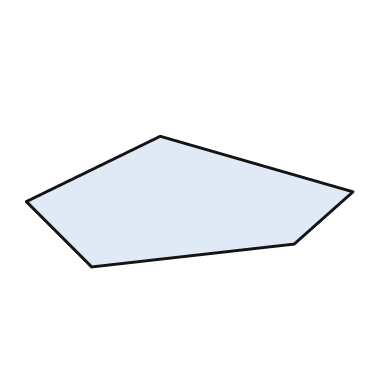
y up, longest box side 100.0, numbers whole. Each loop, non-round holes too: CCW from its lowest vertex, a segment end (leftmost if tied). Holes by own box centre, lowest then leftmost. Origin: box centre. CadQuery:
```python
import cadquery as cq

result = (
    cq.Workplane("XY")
    .moveTo(-30.0, -20.0)
    .lineTo(32.0, -13.0)
    .lineTo(50.0, 3.0)
    .lineTo(-9.0, 20.0)
    .lineTo(-50.0, 0.0)
    .close()
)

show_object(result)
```